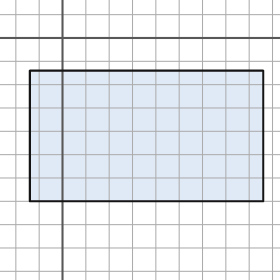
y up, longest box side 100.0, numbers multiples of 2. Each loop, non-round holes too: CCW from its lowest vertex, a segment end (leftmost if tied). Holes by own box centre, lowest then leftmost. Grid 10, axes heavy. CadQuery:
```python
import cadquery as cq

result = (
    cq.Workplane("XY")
    .moveTo(-14.0, -70.0)
    .lineTo(86.0, -70.0)
    .lineTo(86.0, -14.0)
    .lineTo(-14.0, -14.0)
    .close()
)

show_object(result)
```